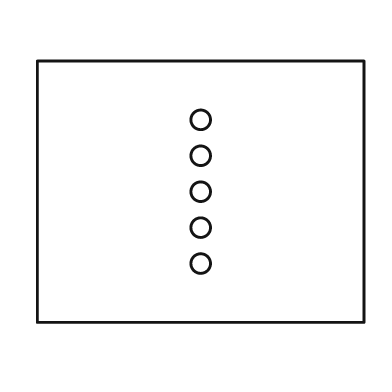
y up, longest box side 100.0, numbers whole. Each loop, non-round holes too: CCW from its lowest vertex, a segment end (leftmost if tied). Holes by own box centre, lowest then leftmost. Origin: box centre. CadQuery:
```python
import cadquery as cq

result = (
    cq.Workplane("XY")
    .moveTo(-50.0, -40.0)
    .lineTo(50.0, -40.0)
    .lineTo(50.0, 40.0)
    .lineTo(-50.0, 40.0)
    .close()
    .moveTo(0.0, -22.0)
    .circle(3.0)
    .moveTo(0.0, -11.0)
    .circle(3.0)
    .moveTo(0.0, 0.0)
    .circle(3.0)
    .moveTo(0.0, 11.0)
    .circle(3.0)
    .moveTo(0.0, 22.0)
    .circle(3.0)
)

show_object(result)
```